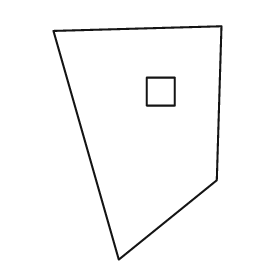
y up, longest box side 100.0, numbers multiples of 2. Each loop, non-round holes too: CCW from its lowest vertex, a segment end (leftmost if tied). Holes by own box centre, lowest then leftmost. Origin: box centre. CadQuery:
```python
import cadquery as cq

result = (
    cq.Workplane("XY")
    .moveTo(-8.0, -50.0)
    .lineTo(34.0, -16.0)
    .lineTo(36.0, 50.0)
    .lineTo(-36.0, 48.0)
    .close()
    .moveTo(4.0, 16.0)
    .lineTo(16.0, 16.0)
    .lineTo(16.0, 28.0)
    .lineTo(4.0, 28.0)
    .close()
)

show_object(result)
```